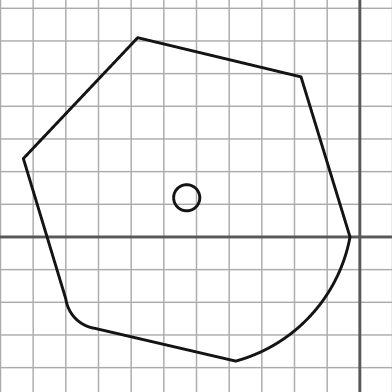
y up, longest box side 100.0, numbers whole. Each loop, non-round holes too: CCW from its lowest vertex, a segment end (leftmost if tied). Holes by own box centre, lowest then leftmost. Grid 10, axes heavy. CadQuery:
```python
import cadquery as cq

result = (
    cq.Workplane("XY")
    .moveTo(-38.0, -38.0)
    .threePointArc((-15.0, -24.0), (-3.0, 0.0))
    .lineTo(-18.0, 49.0)
    .lineTo(-68.0, 61.0)
    .lineTo(-103.0, 24.0)
    .lineTo(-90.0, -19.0)
    .threePointArc((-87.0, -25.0), (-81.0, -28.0))
    .close()
    .moveTo(-53.0, 12.0)
    .circle(4.0)
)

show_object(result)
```